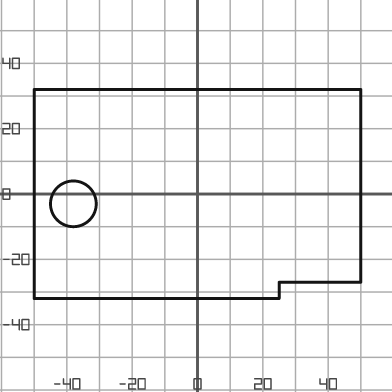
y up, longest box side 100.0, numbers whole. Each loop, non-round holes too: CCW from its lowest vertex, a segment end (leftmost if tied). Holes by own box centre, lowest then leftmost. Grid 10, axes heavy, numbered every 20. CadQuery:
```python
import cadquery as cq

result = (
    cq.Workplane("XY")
    .moveTo(-50.0, -32.0)
    .lineTo(25.0, -32.0)
    .lineTo(25.0, -27.0)
    .lineTo(50.0, -27.0)
    .lineTo(50.0, 32.0)
    .lineTo(-50.0, 32.0)
    .close()
    .moveTo(-38.0, -3.0)
    .circle(7.0)
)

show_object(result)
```